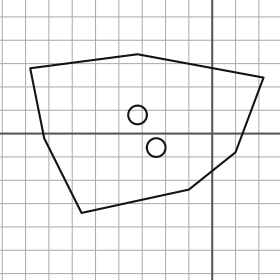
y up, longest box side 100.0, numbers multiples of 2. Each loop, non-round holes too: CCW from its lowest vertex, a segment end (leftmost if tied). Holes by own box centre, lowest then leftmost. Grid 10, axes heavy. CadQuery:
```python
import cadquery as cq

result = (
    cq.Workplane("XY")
    .moveTo(-56.0, -34.0)
    .lineTo(-10.0, -24.0)
    .lineTo(10.0, -8.0)
    .lineTo(22.0, 24.0)
    .lineTo(-32.0, 34.0)
    .lineTo(-78.0, 28.0)
    .lineTo(-72.0, -2.0)
    .close()
    .moveTo(-24.0, -6.0)
    .circle(4.0)
    .moveTo(-32.0, 8.0)
    .circle(4.0)
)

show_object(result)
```